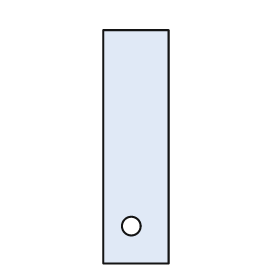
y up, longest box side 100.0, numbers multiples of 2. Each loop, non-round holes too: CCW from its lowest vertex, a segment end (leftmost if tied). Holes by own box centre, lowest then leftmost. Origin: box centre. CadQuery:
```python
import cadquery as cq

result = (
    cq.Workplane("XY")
    .moveTo(-14.0, -50.0)
    .lineTo(14.0, -50.0)
    .lineTo(14.0, 50.0)
    .lineTo(-14.0, 50.0)
    .close()
    .moveTo(-2.0, -34.0)
    .circle(4.0)
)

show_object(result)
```